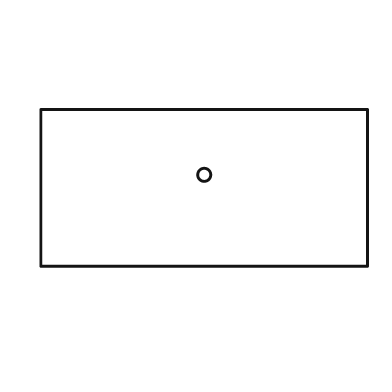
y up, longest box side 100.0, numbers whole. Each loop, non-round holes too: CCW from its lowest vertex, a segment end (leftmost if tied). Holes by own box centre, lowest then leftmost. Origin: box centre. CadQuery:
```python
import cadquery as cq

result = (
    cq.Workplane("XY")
    .moveTo(-50.0, -24.0)
    .lineTo(50.0, -24.0)
    .lineTo(50.0, 24.0)
    .lineTo(-50.0, 24.0)
    .close()
    .moveTo(0.0, 4.0)
    .circle(2.0)
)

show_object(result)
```